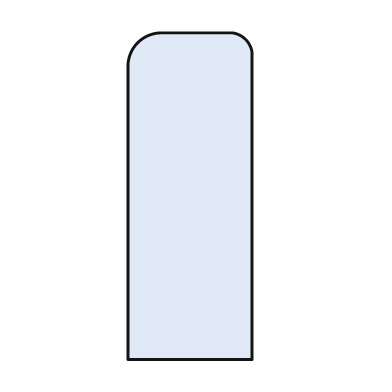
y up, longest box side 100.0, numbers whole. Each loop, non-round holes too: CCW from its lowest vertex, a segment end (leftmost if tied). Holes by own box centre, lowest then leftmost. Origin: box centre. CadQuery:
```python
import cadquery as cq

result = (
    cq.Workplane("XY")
    .moveTo(-19.0, -50.0)
    .lineTo(19.0, -50.0)
    .lineTo(19.0, 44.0)
    .threePointArc((17.0, 48.0), (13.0, 50.0))
    .lineTo(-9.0, 50.0)
    .threePointArc((-16.0, 47.0), (-19.0, 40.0))
    .close()
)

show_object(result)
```